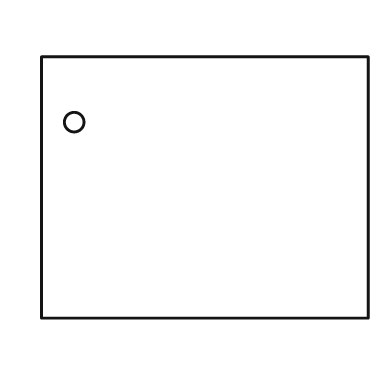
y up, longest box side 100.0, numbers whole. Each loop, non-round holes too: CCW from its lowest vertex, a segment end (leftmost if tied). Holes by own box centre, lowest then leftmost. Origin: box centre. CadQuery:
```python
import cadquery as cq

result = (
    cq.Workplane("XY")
    .moveTo(-50.0, -40.0)
    .lineTo(50.0, -40.0)
    .lineTo(50.0, 40.0)
    .lineTo(-50.0, 40.0)
    .close()
    .moveTo(-40.0, 20.0)
    .circle(3.0)
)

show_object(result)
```